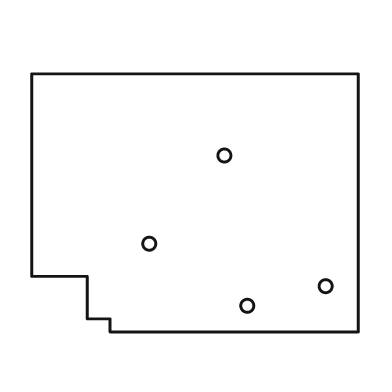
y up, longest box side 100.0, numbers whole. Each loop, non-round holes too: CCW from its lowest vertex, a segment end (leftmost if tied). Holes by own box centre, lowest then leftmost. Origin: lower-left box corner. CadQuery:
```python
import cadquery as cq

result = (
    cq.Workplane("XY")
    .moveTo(24.0, 0.0)
    .lineTo(100.0, 0.0)
    .lineTo(100.0, 79.0)
    .lineTo(0.0, 79.0)
    .lineTo(0.0, 17.0)
    .lineTo(17.0, 17.0)
    .lineTo(17.0, 4.0)
    .lineTo(24.0, 4.0)
    .close()
    .moveTo(66.0, 8.0)
    .circle(2.0)
    .moveTo(90.0, 14.0)
    .circle(2.0)
    .moveTo(36.0, 27.0)
    .circle(2.0)
    .moveTo(59.0, 54.0)
    .circle(2.0)
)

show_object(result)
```